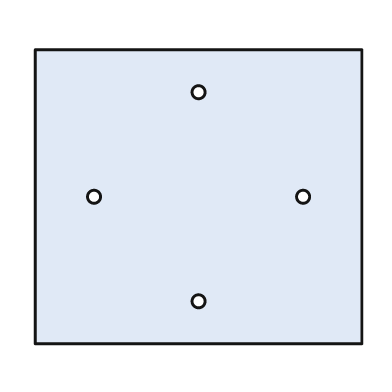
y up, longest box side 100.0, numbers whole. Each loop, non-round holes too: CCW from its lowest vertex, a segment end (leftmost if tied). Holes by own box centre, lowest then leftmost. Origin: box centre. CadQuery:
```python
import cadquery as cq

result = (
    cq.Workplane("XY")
    .moveTo(-50.0, -45.0)
    .lineTo(50.0, -45.0)
    .lineTo(50.0, 45.0)
    .lineTo(-50.0, 45.0)
    .close()
    .moveTo(0.0, -32.0)
    .circle(2.0)
    .moveTo(-32.0, 0.0)
    .circle(2.0)
    .moveTo(32.0, 0.0)
    .circle(2.0)
    .moveTo(0.0, 32.0)
    .circle(2.0)
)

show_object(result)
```